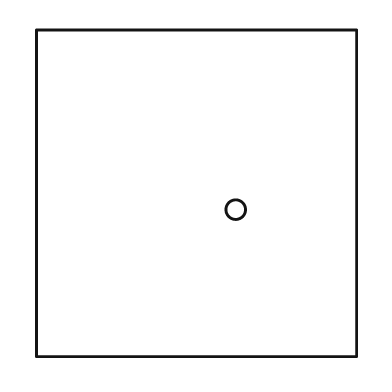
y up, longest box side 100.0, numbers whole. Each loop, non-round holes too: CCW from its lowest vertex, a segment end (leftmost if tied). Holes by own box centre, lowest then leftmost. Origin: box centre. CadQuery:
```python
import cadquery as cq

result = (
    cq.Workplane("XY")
    .moveTo(-49.0, -50.0)
    .lineTo(49.0, -50.0)
    .lineTo(49.0, 50.0)
    .lineTo(-49.0, 50.0)
    .close()
    .moveTo(12.0, -5.0)
    .circle(3.0)
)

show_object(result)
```